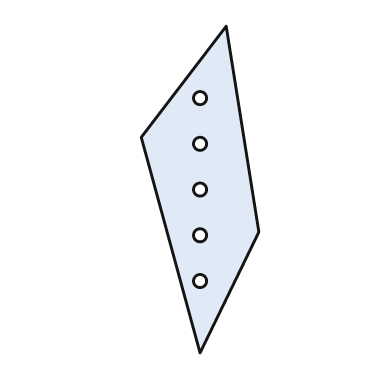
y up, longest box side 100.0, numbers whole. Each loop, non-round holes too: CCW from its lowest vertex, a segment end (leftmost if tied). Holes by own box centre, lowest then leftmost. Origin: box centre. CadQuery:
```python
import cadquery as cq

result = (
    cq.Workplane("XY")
    .moveTo(0.0, -50.0)
    .lineTo(18.0, -13.0)
    .lineTo(8.0, 50.0)
    .lineTo(-18.0, 16.0)
    .close()
    .moveTo(0.0, -28.0)
    .circle(2.0)
    .moveTo(0.0, -14.0)
    .circle(2.0)
    .moveTo(0.0, 0.0)
    .circle(2.0)
    .moveTo(0.0, 14.0)
    .circle(2.0)
    .moveTo(0.0, 28.0)
    .circle(2.0)
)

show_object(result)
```